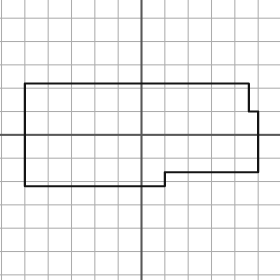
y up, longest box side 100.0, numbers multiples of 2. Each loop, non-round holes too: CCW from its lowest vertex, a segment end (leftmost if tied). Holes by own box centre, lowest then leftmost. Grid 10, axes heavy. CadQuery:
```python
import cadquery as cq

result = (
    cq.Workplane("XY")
    .moveTo(-50.0, -22.0)
    .lineTo(10.0, -22.0)
    .lineTo(10.0, -16.0)
    .lineTo(50.0, -16.0)
    .lineTo(50.0, 10.0)
    .lineTo(46.0, 10.0)
    .lineTo(46.0, 22.0)
    .lineTo(-50.0, 22.0)
    .close()
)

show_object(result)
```